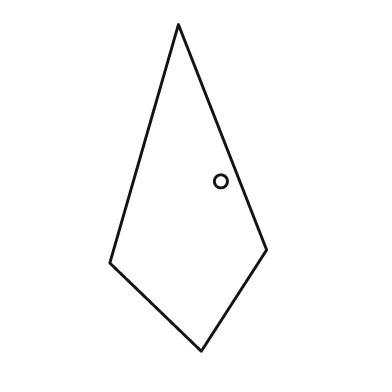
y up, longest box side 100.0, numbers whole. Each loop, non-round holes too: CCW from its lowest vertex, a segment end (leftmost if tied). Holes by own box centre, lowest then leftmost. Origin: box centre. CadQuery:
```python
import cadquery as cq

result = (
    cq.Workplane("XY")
    .moveTo(4.0, -50.0)
    .lineTo(24.0, -19.0)
    .lineTo(-3.0, 50.0)
    .lineTo(-24.0, -23.0)
    .close()
    .moveTo(10.0, 2.0)
    .circle(2.0)
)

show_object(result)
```